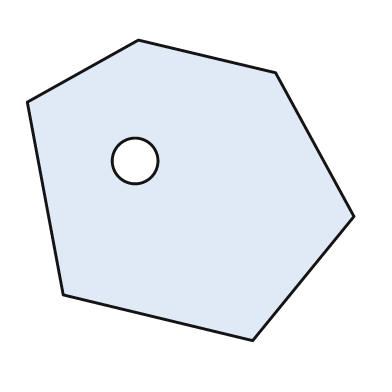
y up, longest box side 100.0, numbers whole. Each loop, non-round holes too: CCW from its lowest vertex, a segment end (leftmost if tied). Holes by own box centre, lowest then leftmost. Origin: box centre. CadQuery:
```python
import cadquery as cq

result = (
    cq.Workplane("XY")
    .moveTo(19.0, -46.0)
    .lineTo(50.0, -8.0)
    .lineTo(26.0, 36.0)
    .lineTo(-16.0, 46.0)
    .lineTo(-50.0, 27.0)
    .lineTo(-39.0, -32.0)
    .close()
    .moveTo(-17.0, 9.0)
    .circle(7.0)
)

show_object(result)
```